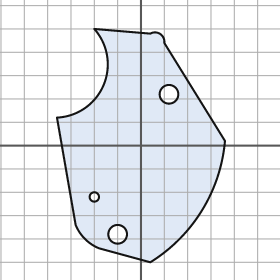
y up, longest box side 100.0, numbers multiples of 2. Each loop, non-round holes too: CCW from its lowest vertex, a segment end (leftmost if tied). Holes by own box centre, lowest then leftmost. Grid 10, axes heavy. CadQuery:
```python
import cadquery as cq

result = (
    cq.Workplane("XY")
    .moveTo(4.0, -50.0)
    .threePointArc((26.0, -28.0), (36.0, 2.0))
    .lineTo(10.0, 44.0)
    .threePointArc((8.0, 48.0), (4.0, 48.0))
    .lineTo(-20.0, 50.0)
    .threePointArc((-16.0, 26.0), (-36.0, 12.0))
    .lineTo(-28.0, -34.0)
    .threePointArc((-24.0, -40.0), (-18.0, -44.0))
    .close()
    .moveTo(-10.0, -38.0)
    .circle(4.0)
    .moveTo(-20.0, -22.0)
    .circle(2.0)
    .moveTo(12.0, 22.0)
    .circle(4.0)
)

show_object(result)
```